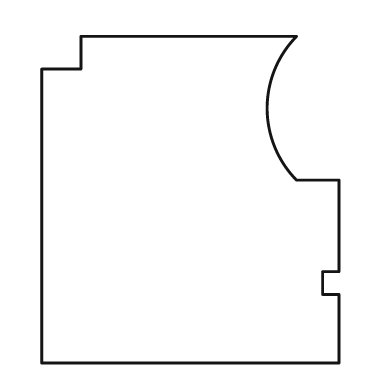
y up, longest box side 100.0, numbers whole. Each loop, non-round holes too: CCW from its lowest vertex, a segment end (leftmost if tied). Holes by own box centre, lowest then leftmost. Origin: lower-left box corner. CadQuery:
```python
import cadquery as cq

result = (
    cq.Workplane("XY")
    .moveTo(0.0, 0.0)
    .lineTo(91.0, 0.0)
    .lineTo(91.0, 21.0)
    .lineTo(86.0, 21.0)
    .lineTo(86.0, 28.0)
    .lineTo(91.0, 28.0)
    .lineTo(91.0, 56.0)
    .lineTo(78.0, 56.0)
    .threePointArc((69.0, 78.0), (78.0, 100.0))
    .lineTo(12.0, 100.0)
    .lineTo(12.0, 90.0)
    .lineTo(0.0, 90.0)
    .close()
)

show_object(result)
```